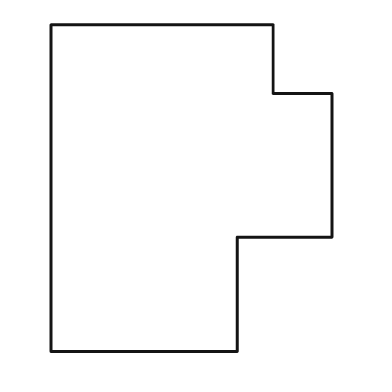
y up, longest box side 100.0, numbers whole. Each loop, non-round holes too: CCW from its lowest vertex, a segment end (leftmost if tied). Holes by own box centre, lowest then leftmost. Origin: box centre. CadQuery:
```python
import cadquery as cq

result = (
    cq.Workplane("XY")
    .moveTo(-43.0, -50.0)
    .lineTo(14.0, -50.0)
    .lineTo(14.0, -15.0)
    .lineTo(43.0, -15.0)
    .lineTo(43.0, 29.0)
    .lineTo(25.0, 29.0)
    .lineTo(25.0, 50.0)
    .lineTo(-43.0, 50.0)
    .close()
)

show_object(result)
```